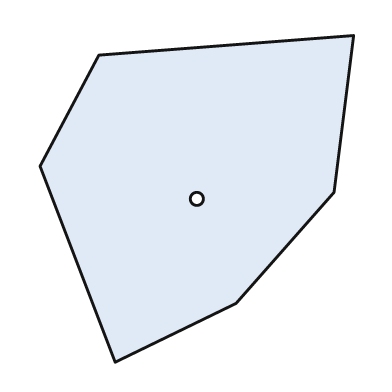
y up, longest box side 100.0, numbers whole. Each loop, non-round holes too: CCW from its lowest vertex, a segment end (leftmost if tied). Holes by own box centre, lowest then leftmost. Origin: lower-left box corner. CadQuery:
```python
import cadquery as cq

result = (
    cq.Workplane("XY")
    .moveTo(23.0, 0.0)
    .lineTo(60.0, 18.0)
    .lineTo(90.0, 52.0)
    .lineTo(96.0, 100.0)
    .lineTo(18.0, 94.0)
    .lineTo(0.0, 60.0)
    .close()
    .moveTo(48.0, 50.0)
    .circle(2.0)
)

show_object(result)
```